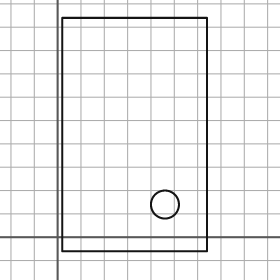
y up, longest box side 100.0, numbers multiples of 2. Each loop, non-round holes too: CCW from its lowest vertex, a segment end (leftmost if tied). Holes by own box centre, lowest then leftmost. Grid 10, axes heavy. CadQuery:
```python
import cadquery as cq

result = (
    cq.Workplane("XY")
    .moveTo(2.0, -6.0)
    .lineTo(64.0, -6.0)
    .lineTo(64.0, 94.0)
    .lineTo(2.0, 94.0)
    .close()
    .moveTo(46.0, 14.0)
    .circle(6.0)
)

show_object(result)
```